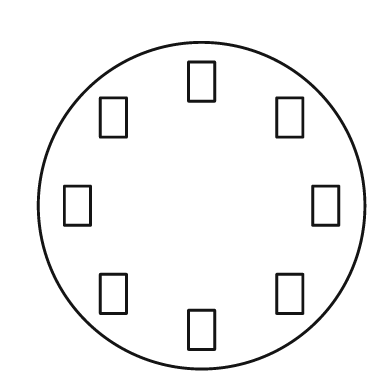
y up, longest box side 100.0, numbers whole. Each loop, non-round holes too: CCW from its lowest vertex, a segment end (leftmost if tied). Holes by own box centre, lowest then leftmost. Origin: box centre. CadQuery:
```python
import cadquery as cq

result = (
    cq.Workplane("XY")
    .moveTo(0.0, 0.0)
    .circle(50.0)
    .moveTo(-4.0, -44.0)
    .lineTo(4.0, -44.0)
    .lineTo(4.0, -32.0)
    .lineTo(-4.0, -32.0)
    .close()
    .moveTo(-31.0, -33.0)
    .lineTo(-23.0, -33.0)
    .lineTo(-23.0, -21.0)
    .lineTo(-31.0, -21.0)
    .close()
    .moveTo(23.0, -33.0)
    .lineTo(31.0, -33.0)
    .lineTo(31.0, -21.0)
    .lineTo(23.0, -21.0)
    .close()
    .moveTo(-42.0, -6.0)
    .lineTo(-34.0, -6.0)
    .lineTo(-34.0, 6.0)
    .lineTo(-42.0, 6.0)
    .close()
    .moveTo(34.0, -6.0)
    .lineTo(42.0, -6.0)
    .lineTo(42.0, 6.0)
    .lineTo(34.0, 6.0)
    .close()
    .moveTo(-31.0, 21.0)
    .lineTo(-23.0, 21.0)
    .lineTo(-23.0, 33.0)
    .lineTo(-31.0, 33.0)
    .close()
    .moveTo(23.0, 21.0)
    .lineTo(31.0, 21.0)
    .lineTo(31.0, 33.0)
    .lineTo(23.0, 33.0)
    .close()
    .moveTo(-4.0, 32.0)
    .lineTo(4.0, 32.0)
    .lineTo(4.0, 44.0)
    .lineTo(-4.0, 44.0)
    .close()
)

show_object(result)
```